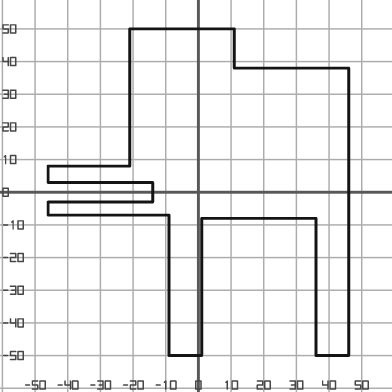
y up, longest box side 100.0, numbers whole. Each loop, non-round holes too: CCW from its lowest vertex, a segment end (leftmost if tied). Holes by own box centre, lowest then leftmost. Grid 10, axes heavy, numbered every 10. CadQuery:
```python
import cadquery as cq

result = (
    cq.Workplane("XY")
    .moveTo(-9.0, -50.0)
    .lineTo(1.0, -50.0)
    .lineTo(1.0, -8.0)
    .lineTo(36.0, -8.0)
    .lineTo(36.0, -50.0)
    .lineTo(46.0, -50.0)
    .lineTo(46.0, 38.0)
    .lineTo(11.0, 38.0)
    .lineTo(11.0, 50.0)
    .lineTo(-21.0, 50.0)
    .lineTo(-21.0, 8.0)
    .lineTo(-46.0, 8.0)
    .lineTo(-46.0, 3.0)
    .lineTo(-14.0, 3.0)
    .lineTo(-14.0, -3.0)
    .lineTo(-46.0, -3.0)
    .lineTo(-46.0, -7.0)
    .lineTo(-9.0, -7.0)
    .close()
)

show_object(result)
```